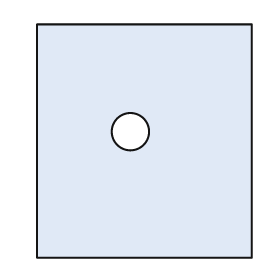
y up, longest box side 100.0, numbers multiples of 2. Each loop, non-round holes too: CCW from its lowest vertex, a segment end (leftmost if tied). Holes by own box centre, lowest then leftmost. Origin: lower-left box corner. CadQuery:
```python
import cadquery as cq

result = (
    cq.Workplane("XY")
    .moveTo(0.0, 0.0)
    .lineTo(92.0, 0.0)
    .lineTo(92.0, 100.0)
    .lineTo(0.0, 100.0)
    .close()
    .moveTo(40.0, 54.0)
    .circle(8.0)
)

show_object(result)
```